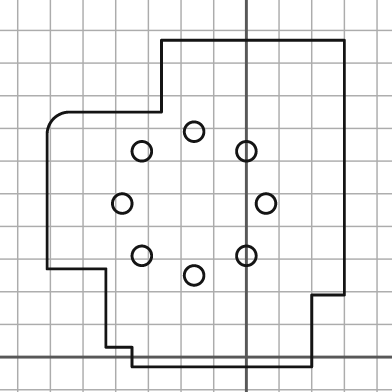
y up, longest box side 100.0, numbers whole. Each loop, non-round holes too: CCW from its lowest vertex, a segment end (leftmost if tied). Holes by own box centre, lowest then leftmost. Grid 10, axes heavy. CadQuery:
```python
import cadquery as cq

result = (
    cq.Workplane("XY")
    .moveTo(-35.0, -3.0)
    .lineTo(20.0, -3.0)
    .lineTo(20.0, 19.0)
    .lineTo(30.0, 19.0)
    .lineTo(30.0, 97.0)
    .lineTo(-26.0, 97.0)
    .lineTo(-26.0, 75.0)
    .lineTo(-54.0, 75.0)
    .threePointArc((-59.0, 73.0), (-61.0, 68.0))
    .lineTo(-61.0, 27.0)
    .lineTo(-43.0, 27.0)
    .lineTo(-43.0, 3.0)
    .lineTo(-35.0, 3.0)
    .close()
    .moveTo(-16.0, 25.0)
    .circle(3.0)
    .moveTo(-32.0, 31.0)
    .circle(3.0)
    .moveTo(0.0, 31.0)
    .circle(3.0)
    .moveTo(-38.0, 47.0)
    .circle(3.0)
    .moveTo(6.0, 47.0)
    .circle(3.0)
    .moveTo(-32.0, 63.0)
    .circle(3.0)
    .moveTo(0.0, 63.0)
    .circle(3.0)
    .moveTo(-16.0, 69.0)
    .circle(3.0)
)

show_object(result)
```